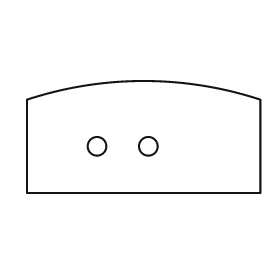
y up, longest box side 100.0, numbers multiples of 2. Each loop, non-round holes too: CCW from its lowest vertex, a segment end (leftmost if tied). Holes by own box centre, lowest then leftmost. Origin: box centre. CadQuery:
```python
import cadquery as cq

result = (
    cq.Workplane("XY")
    .moveTo(-50.0, -24.0)
    .lineTo(50.0, -24.0)
    .lineTo(50.0, 16.0)
    .threePointArc((0.0, 24.0), (-50.0, 16.0))
    .close()
    .moveTo(-20.0, -4.0)
    .circle(4.0)
    .moveTo(2.0, -4.0)
    .circle(4.0)
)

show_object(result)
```